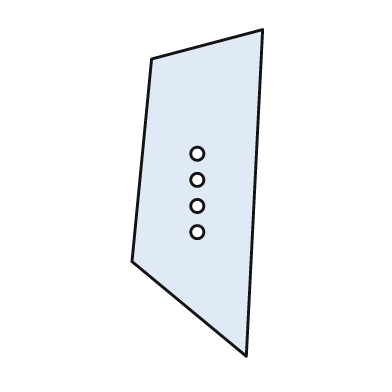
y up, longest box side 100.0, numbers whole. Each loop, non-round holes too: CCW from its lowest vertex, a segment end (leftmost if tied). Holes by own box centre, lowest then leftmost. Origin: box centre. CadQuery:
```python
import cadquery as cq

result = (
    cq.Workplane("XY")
    .moveTo(15.0, -50.0)
    .lineTo(20.0, 50.0)
    .lineTo(-14.0, 41.0)
    .lineTo(-20.0, -21.0)
    .close()
    .moveTo(0.0, -12.0)
    .circle(2.0)
    .moveTo(0.0, -4.0)
    .circle(2.0)
    .moveTo(0.0, 4.0)
    .circle(2.0)
    .moveTo(0.0, 12.0)
    .circle(2.0)
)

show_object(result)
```